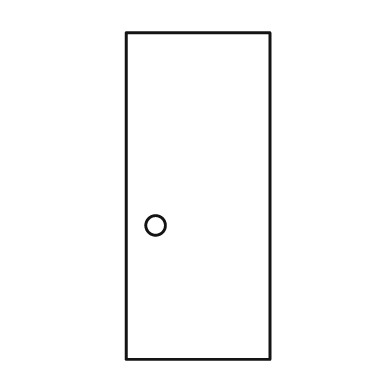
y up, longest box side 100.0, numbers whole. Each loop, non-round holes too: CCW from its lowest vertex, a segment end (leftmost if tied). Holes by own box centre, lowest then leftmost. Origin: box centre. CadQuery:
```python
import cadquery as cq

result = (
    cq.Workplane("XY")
    .moveTo(-22.0, -50.0)
    .lineTo(22.0, -50.0)
    .lineTo(22.0, 50.0)
    .lineTo(-22.0, 50.0)
    .close()
    .moveTo(-13.0, -9.0)
    .circle(3.0)
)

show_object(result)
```